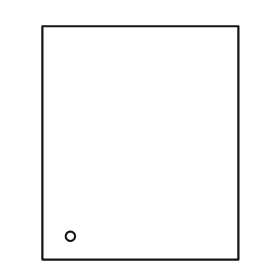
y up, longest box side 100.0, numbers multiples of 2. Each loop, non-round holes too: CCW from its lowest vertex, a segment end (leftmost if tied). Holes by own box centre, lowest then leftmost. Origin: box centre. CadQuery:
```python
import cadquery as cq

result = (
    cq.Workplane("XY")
    .moveTo(-42.0, -50.0)
    .lineTo(42.0, -50.0)
    .lineTo(42.0, 50.0)
    .lineTo(-42.0, 50.0)
    .close()
    .moveTo(-30.0, -40.0)
    .circle(2.0)
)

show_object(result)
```